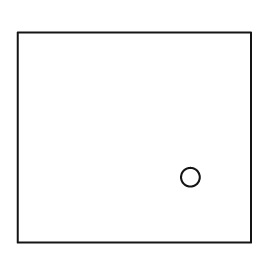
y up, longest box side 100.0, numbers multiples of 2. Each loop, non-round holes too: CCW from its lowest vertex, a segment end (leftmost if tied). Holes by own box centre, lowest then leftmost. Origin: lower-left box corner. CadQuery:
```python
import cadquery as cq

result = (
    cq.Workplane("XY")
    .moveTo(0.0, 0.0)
    .lineTo(100.0, 0.0)
    .lineTo(100.0, 90.0)
    .lineTo(0.0, 90.0)
    .close()
    .moveTo(74.0, 28.0)
    .circle(4.0)
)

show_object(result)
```